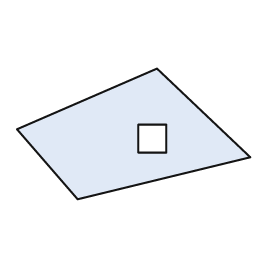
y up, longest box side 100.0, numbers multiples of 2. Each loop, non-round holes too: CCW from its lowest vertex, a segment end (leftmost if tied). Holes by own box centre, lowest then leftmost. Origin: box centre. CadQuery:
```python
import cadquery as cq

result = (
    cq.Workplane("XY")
    .moveTo(-24.0, -28.0)
    .lineTo(50.0, -10.0)
    .lineTo(10.0, 28.0)
    .lineTo(-50.0, 2.0)
    .close()
    .moveTo(2.0, -8.0)
    .lineTo(14.0, -8.0)
    .lineTo(14.0, 4.0)
    .lineTo(2.0, 4.0)
    .close()
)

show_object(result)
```